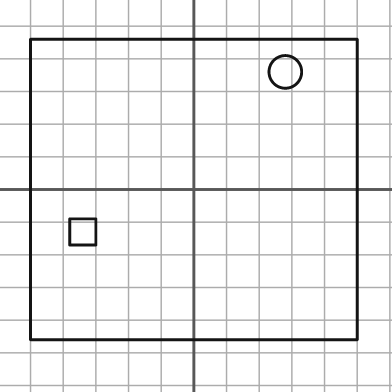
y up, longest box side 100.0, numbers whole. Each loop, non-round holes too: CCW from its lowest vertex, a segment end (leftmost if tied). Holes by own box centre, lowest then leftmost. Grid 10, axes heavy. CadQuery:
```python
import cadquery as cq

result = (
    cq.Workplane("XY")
    .moveTo(-50.0, -46.0)
    .lineTo(50.0, -46.0)
    .lineTo(50.0, 46.0)
    .lineTo(-50.0, 46.0)
    .close()
    .moveTo(-38.0, -17.0)
    .lineTo(-30.0, -17.0)
    .lineTo(-30.0, -9.0)
    .lineTo(-38.0, -9.0)
    .close()
    .moveTo(28.0, 36.0)
    .circle(5.0)
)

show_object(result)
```